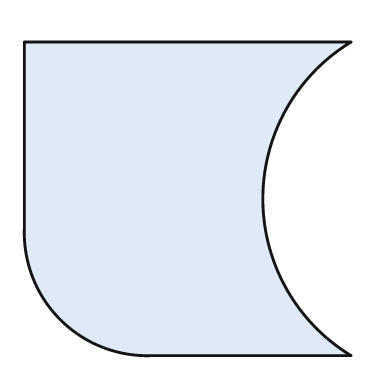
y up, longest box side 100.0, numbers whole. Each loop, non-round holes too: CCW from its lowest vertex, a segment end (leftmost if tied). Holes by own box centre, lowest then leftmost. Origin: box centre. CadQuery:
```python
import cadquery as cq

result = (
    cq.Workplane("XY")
    .moveTo(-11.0, -48.0)
    .lineTo(50.0, -48.0)
    .threePointArc((23.0, 0.0), (50.0, 48.0))
    .lineTo(-50.0, 48.0)
    .lineTo(-50.0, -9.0)
    .threePointArc((-39.0, -37.0), (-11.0, -48.0))
    .close()
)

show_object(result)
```